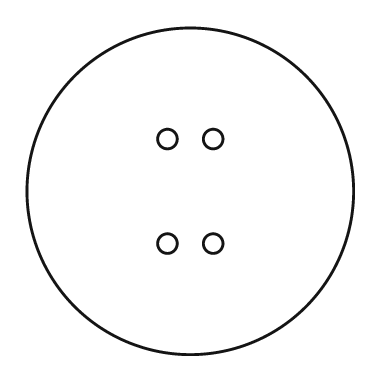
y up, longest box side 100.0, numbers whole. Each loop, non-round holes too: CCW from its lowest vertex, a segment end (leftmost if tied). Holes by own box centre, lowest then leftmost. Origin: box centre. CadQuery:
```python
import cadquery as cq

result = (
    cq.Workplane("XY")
    .moveTo(0.0, 0.0)
    .circle(50.0)
    .moveTo(-7.0, -16.0)
    .circle(3.0)
    .moveTo(7.0, -16.0)
    .circle(3.0)
    .moveTo(-7.0, 16.0)
    .circle(3.0)
    .moveTo(7.0, 16.0)
    .circle(3.0)
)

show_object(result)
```